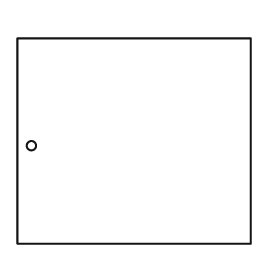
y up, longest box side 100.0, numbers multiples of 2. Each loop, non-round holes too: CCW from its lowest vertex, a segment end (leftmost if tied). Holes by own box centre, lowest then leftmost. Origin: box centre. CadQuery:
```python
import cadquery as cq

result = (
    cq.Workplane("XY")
    .moveTo(-50.0, -44.0)
    .lineTo(50.0, -44.0)
    .lineTo(50.0, 44.0)
    .lineTo(-50.0, 44.0)
    .close()
    .moveTo(-44.0, -2.0)
    .circle(2.0)
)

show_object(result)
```